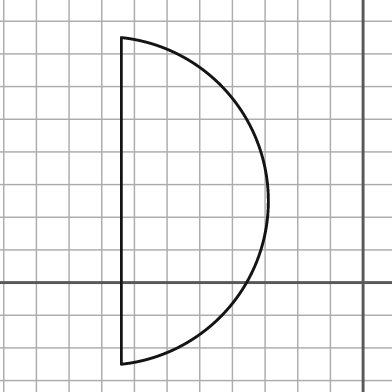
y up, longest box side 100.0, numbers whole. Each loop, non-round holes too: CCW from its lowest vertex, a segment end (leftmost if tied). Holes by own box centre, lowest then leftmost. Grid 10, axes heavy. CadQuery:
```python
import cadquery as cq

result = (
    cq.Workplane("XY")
    .moveTo(-74.0, -25.0)
    .threePointArc((-29.0, 25.0), (-74.0, 75.0))
    .close()
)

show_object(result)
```